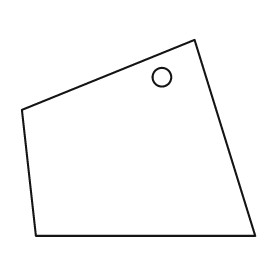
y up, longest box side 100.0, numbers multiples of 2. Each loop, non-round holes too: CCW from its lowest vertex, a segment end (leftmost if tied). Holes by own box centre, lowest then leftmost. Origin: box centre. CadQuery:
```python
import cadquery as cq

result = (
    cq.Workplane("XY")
    .moveTo(-44.0, -42.0)
    .lineTo(50.0, -42.0)
    .lineTo(24.0, 42.0)
    .lineTo(-50.0, 12.0)
    .close()
    .moveTo(10.0, 26.0)
    .circle(4.0)
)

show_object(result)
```